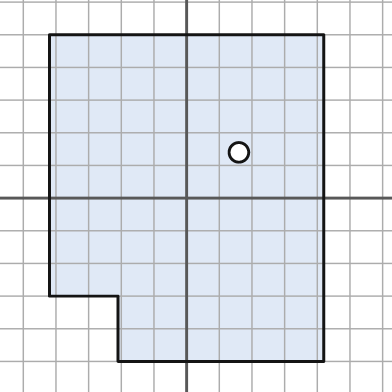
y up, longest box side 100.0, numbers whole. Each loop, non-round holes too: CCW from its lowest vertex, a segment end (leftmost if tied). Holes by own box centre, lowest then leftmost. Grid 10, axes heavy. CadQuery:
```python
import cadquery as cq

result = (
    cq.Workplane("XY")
    .moveTo(-21.0, -50.0)
    .lineTo(42.0, -50.0)
    .lineTo(42.0, 50.0)
    .lineTo(-42.0, 50.0)
    .lineTo(-42.0, -30.0)
    .lineTo(-21.0, -30.0)
    .close()
    .moveTo(16.0, 14.0)
    .circle(3.0)
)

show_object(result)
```